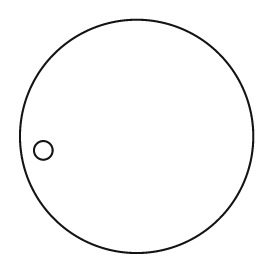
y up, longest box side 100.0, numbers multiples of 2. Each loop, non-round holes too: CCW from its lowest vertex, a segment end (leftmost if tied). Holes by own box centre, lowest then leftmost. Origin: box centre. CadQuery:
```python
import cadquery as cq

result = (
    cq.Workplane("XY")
    .moveTo(0.0, 0.0)
    .circle(50.0)
    .moveTo(-40.0, -6.0)
    .circle(4.0)
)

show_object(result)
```